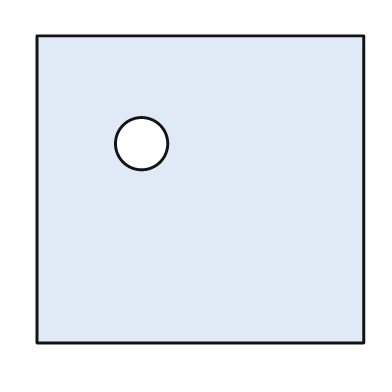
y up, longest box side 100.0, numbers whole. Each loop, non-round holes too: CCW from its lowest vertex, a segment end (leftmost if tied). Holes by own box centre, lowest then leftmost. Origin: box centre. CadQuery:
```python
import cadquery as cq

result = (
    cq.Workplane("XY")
    .moveTo(-50.0, -47.0)
    .lineTo(50.0, -47.0)
    .lineTo(50.0, 47.0)
    .lineTo(-50.0, 47.0)
    .close()
    .moveTo(-18.0, 14.0)
    .circle(8.0)
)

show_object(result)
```